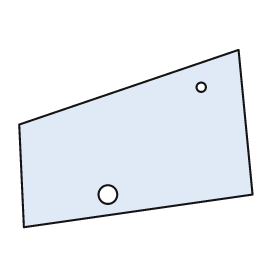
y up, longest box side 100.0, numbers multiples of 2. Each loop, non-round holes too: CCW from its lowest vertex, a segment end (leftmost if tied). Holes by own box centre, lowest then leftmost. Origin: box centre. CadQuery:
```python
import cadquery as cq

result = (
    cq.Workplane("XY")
    .moveTo(-48.0, -38.0)
    .lineTo(50.0, -24.0)
    .lineTo(44.0, 38.0)
    .lineTo(-50.0, 6.0)
    .close()
    .moveTo(-12.0, -24.0)
    .circle(4.0)
    .moveTo(28.0, 22.0)
    .circle(2.0)
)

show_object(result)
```